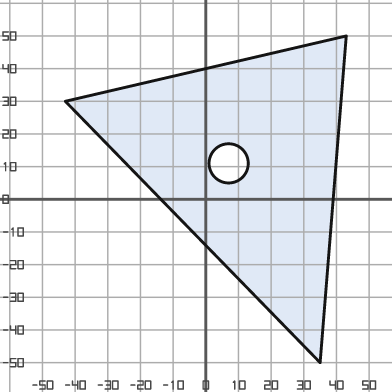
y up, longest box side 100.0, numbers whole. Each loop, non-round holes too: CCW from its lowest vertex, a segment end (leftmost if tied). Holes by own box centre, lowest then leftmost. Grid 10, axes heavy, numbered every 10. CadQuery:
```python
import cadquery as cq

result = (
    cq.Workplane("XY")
    .moveTo(35.0, -50.0)
    .lineTo(43.0, 50.0)
    .lineTo(-43.0, 30.0)
    .close()
    .moveTo(7.0, 11.0)
    .circle(6.0)
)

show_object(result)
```